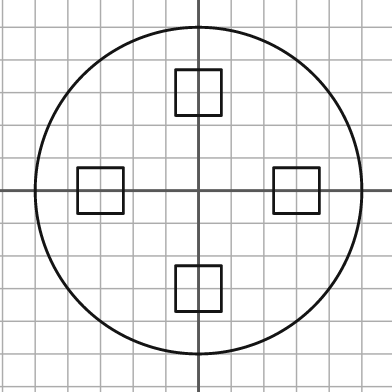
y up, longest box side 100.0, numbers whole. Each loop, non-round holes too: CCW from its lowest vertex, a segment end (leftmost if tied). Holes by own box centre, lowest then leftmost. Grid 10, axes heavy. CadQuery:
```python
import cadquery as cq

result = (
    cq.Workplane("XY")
    .moveTo(0.0, 0.0)
    .circle(50.0)
    .moveTo(-7.0, -37.0)
    .lineTo(7.0, -37.0)
    .lineTo(7.0, -23.0)
    .lineTo(-7.0, -23.0)
    .close()
    .moveTo(-37.0, -7.0)
    .lineTo(-23.0, -7.0)
    .lineTo(-23.0, 7.0)
    .lineTo(-37.0, 7.0)
    .close()
    .moveTo(23.0, -7.0)
    .lineTo(37.0, -7.0)
    .lineTo(37.0, 7.0)
    .lineTo(23.0, 7.0)
    .close()
    .moveTo(-7.0, 23.0)
    .lineTo(7.0, 23.0)
    .lineTo(7.0, 37.0)
    .lineTo(-7.0, 37.0)
    .close()
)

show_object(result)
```